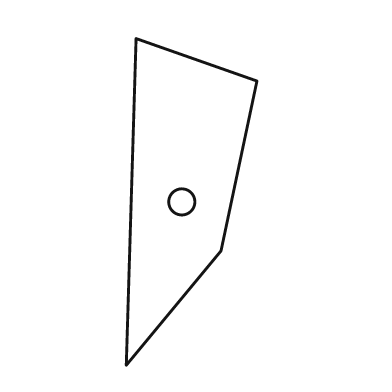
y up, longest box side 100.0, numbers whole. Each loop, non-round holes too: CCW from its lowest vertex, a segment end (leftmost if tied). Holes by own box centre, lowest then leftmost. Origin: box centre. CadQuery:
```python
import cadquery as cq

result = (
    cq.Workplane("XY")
    .moveTo(-20.0, -50.0)
    .lineTo(9.0, -15.0)
    .lineTo(20.0, 37.0)
    .lineTo(-17.0, 50.0)
    .close()
    .moveTo(-3.0, 0.0)
    .circle(4.0)
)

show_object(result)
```